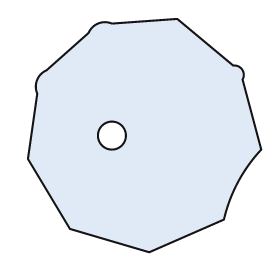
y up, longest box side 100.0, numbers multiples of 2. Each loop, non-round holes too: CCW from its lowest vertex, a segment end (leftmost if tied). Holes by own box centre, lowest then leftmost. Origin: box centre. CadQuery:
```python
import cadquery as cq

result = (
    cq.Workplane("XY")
    .moveTo(2.0, -50.0)
    .lineTo(34.0, -36.0)
    .threePointArc((40.0, -20.0), (50.0, -6.0))
    .lineTo(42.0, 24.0)
    .threePointArc((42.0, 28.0), (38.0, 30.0))
    .lineTo(14.0, 50.0)
    .lineTo(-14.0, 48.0)
    .threePointArc((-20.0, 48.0), (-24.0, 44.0))
    .lineTo(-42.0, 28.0)
    .threePointArc((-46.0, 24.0), (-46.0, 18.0))
    .lineTo(-50.0, -10.0)
    .lineTo(-32.0, -40.0)
    .close()
    .moveTo(-14.0, 0.0)
    .circle(6.0)
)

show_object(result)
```